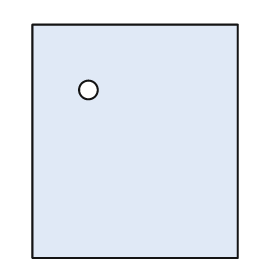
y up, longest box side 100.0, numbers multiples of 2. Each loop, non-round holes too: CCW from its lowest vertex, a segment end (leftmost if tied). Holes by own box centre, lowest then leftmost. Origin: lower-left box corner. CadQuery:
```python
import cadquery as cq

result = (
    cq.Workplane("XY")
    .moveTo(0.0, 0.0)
    .lineTo(88.0, 0.0)
    .lineTo(88.0, 100.0)
    .lineTo(0.0, 100.0)
    .close()
    .moveTo(24.0, 72.0)
    .circle(4.0)
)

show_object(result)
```